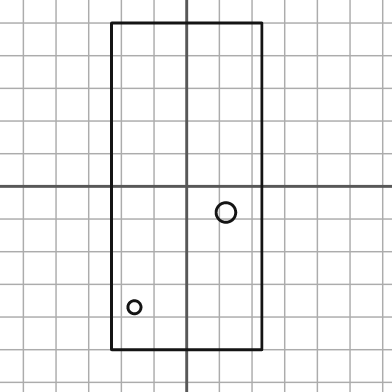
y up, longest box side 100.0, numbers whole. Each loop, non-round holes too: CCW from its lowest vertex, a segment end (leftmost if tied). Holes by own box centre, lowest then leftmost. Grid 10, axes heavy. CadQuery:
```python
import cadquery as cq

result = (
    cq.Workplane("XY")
    .moveTo(-23.0, -50.0)
    .lineTo(23.0, -50.0)
    .lineTo(23.0, 50.0)
    .lineTo(-23.0, 50.0)
    .close()
    .moveTo(-16.0, -37.0)
    .circle(2.0)
    .moveTo(12.0, -8.0)
    .circle(3.0)
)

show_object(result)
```